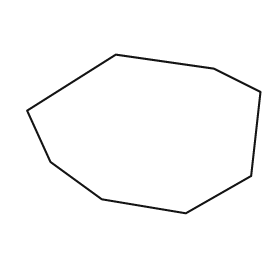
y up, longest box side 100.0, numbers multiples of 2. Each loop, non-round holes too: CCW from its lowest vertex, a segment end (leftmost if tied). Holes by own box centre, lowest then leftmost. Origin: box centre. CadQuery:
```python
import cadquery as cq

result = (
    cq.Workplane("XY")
    .moveTo(18.0, -34.0)
    .lineTo(46.0, -18.0)
    .lineTo(50.0, 18.0)
    .lineTo(30.0, 28.0)
    .lineTo(-12.0, 34.0)
    .lineTo(-50.0, 10.0)
    .lineTo(-40.0, -12.0)
    .lineTo(-18.0, -28.0)
    .close()
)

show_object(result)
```